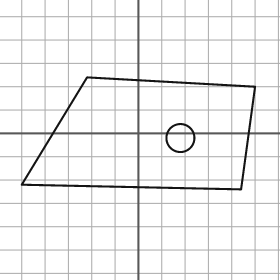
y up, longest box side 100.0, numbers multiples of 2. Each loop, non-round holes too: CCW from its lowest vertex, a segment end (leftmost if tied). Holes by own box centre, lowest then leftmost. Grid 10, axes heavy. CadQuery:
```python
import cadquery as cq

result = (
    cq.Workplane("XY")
    .moveTo(44.0, -24.0)
    .lineTo(50.0, 20.0)
    .lineTo(-22.0, 24.0)
    .lineTo(-50.0, -22.0)
    .close()
    .moveTo(18.0, -2.0)
    .circle(6.0)
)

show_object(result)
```